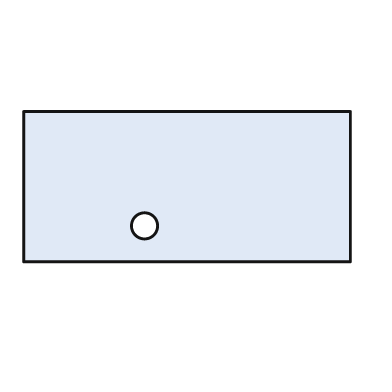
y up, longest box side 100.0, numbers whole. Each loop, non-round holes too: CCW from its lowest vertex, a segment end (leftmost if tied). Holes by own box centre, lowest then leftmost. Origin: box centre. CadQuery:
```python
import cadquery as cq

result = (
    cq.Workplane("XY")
    .moveTo(-50.0, -23.0)
    .lineTo(50.0, -23.0)
    .lineTo(50.0, 23.0)
    .lineTo(-50.0, 23.0)
    .close()
    .moveTo(-13.0, -12.0)
    .circle(4.0)
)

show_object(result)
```